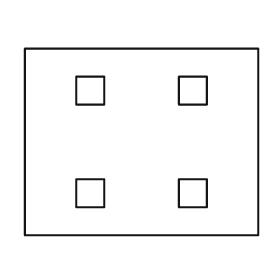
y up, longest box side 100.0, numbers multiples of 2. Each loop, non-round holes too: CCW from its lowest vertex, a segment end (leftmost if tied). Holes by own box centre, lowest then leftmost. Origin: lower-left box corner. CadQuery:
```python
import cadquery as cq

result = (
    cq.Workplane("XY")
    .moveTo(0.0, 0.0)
    .lineTo(100.0, 0.0)
    .lineTo(100.0, 80.0)
    .lineTo(0.0, 80.0)
    .close()
    .moveTo(22.0, 12.0)
    .lineTo(34.0, 12.0)
    .lineTo(34.0, 24.0)
    .lineTo(22.0, 24.0)
    .close()
    .moveTo(66.0, 12.0)
    .lineTo(78.0, 12.0)
    .lineTo(78.0, 24.0)
    .lineTo(66.0, 24.0)
    .close()
    .moveTo(22.0, 56.0)
    .lineTo(34.0, 56.0)
    .lineTo(34.0, 68.0)
    .lineTo(22.0, 68.0)
    .close()
    .moveTo(66.0, 56.0)
    .lineTo(78.0, 56.0)
    .lineTo(78.0, 68.0)
    .lineTo(66.0, 68.0)
    .close()
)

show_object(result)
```